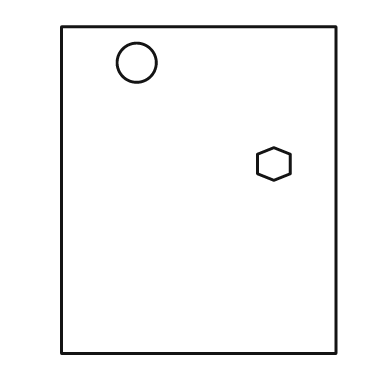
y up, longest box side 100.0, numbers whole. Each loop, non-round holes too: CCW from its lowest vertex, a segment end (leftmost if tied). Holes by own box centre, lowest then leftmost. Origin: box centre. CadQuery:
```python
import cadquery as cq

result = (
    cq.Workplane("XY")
    .moveTo(-42.0, -50.0)
    .lineTo(42.0, -50.0)
    .lineTo(42.0, 50.0)
    .lineTo(-42.0, 50.0)
    .close()
    .moveTo(23.0, 3.0)
    .lineTo(28.0, 5.0)
    .lineTo(28.0, 11.0)
    .lineTo(23.0, 13.0)
    .lineTo(18.0, 11.0)
    .lineTo(18.0, 5.0)
    .close()
    .moveTo(-19.0, 39.0)
    .circle(6.0)
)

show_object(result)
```